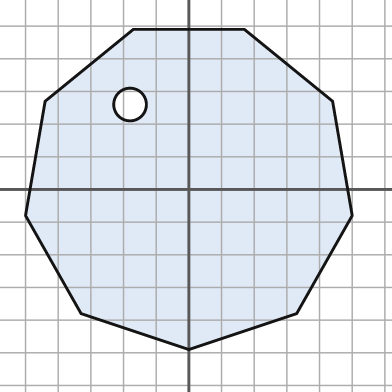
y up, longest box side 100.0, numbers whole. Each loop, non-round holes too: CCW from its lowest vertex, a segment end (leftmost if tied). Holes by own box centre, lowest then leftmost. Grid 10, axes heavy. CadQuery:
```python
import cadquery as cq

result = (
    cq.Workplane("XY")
    .moveTo(0.0, -49.0)
    .lineTo(33.0, -38.0)
    .lineTo(50.0, -8.0)
    .lineTo(44.0, 27.0)
    .lineTo(17.0, 49.0)
    .lineTo(-17.0, 49.0)
    .lineTo(-44.0, 27.0)
    .lineTo(-50.0, -8.0)
    .lineTo(-33.0, -38.0)
    .close()
    .moveTo(-18.0, 26.0)
    .circle(5.0)
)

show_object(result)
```